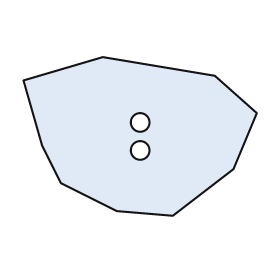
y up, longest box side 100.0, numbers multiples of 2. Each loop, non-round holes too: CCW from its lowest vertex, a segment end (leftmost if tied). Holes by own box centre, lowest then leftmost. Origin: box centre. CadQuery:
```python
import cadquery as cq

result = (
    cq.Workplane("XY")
    .moveTo(14.0, -34.0)
    .lineTo(40.0, -14.0)
    .lineTo(50.0, 10.0)
    .lineTo(32.0, 26.0)
    .lineTo(-16.0, 34.0)
    .lineTo(-50.0, 24.0)
    .lineTo(-42.0, -4.0)
    .lineTo(-34.0, -20.0)
    .lineTo(-10.0, -32.0)
    .close()
    .moveTo(0.0, -6.0)
    .circle(4.0)
    .moveTo(0.0, 6.0)
    .circle(4.0)
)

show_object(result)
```